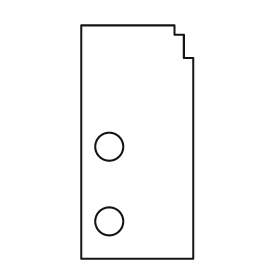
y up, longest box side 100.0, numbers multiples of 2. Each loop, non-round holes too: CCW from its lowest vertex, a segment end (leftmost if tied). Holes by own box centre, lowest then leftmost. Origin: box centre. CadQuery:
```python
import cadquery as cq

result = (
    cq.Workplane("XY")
    .moveTo(-24.0, -50.0)
    .lineTo(24.0, -50.0)
    .lineTo(24.0, 36.0)
    .lineTo(20.0, 36.0)
    .lineTo(20.0, 46.0)
    .lineTo(16.0, 46.0)
    .lineTo(16.0, 50.0)
    .lineTo(-24.0, 50.0)
    .close()
    .moveTo(-12.0, -34.0)
    .circle(6.0)
    .moveTo(-12.0, -2.0)
    .circle(6.0)
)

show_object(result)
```